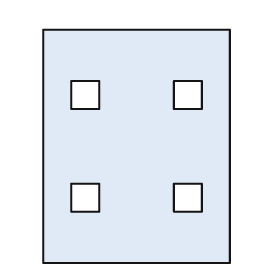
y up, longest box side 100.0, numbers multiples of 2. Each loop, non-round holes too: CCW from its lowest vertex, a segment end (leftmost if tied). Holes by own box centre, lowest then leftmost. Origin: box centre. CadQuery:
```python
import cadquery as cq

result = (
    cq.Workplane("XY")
    .moveTo(-40.0, -50.0)
    .lineTo(40.0, -50.0)
    .lineTo(40.0, 50.0)
    .lineTo(-40.0, 50.0)
    .close()
    .moveTo(-28.0, -28.0)
    .lineTo(-16.0, -28.0)
    .lineTo(-16.0, -16.0)
    .lineTo(-28.0, -16.0)
    .close()
    .moveTo(16.0, -28.0)
    .lineTo(28.0, -28.0)
    .lineTo(28.0, -16.0)
    .lineTo(16.0, -16.0)
    .close()
    .moveTo(-28.0, 16.0)
    .lineTo(-16.0, 16.0)
    .lineTo(-16.0, 28.0)
    .lineTo(-28.0, 28.0)
    .close()
    .moveTo(16.0, 16.0)
    .lineTo(28.0, 16.0)
    .lineTo(28.0, 28.0)
    .lineTo(16.0, 28.0)
    .close()
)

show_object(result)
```